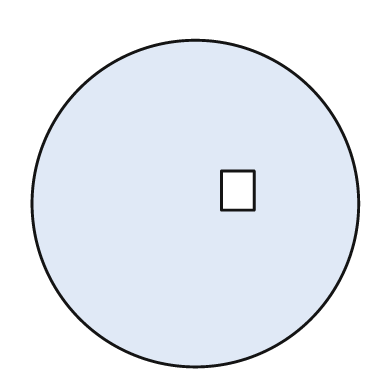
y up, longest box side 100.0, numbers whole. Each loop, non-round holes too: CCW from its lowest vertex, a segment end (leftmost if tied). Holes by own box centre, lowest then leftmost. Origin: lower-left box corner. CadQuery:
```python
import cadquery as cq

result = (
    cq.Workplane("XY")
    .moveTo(50.0, 50.0)
    .circle(50.0)
    .moveTo(58.0, 48.0)
    .lineTo(68.0, 48.0)
    .lineTo(68.0, 60.0)
    .lineTo(58.0, 60.0)
    .close()
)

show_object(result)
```